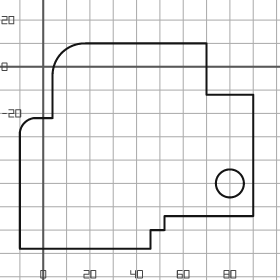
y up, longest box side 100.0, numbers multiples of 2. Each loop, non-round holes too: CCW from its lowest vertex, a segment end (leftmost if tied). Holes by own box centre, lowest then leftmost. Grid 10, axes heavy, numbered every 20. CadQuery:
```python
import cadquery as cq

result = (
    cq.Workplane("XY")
    .moveTo(-10.0, -78.0)
    .lineTo(46.0, -78.0)
    .lineTo(46.0, -70.0)
    .lineTo(52.0, -70.0)
    .lineTo(52.0, -64.0)
    .lineTo(90.0, -64.0)
    .lineTo(90.0, -12.0)
    .lineTo(70.0, -12.0)
    .lineTo(70.0, 10.0)
    .lineTo(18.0, 10.0)
    .threePointArc((8.0, 6.0), (4.0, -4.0))
    .lineTo(4.0, -22.0)
    .lineTo(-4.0, -22.0)
    .threePointArc((-8.0, -24.0), (-10.0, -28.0))
    .close()
    .moveTo(80.0, -50.0)
    .circle(6.0)
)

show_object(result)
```